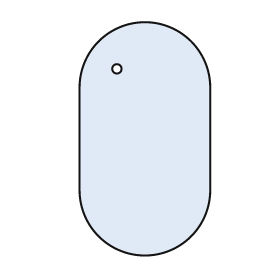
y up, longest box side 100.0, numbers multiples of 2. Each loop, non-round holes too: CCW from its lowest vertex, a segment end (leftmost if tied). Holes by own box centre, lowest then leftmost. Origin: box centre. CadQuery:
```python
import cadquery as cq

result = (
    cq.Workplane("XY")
    .moveTo(-28.0, -22.0)
    .threePointArc((0.0, -50.0), (28.0, -22.0))
    .lineTo(28.0, 22.0)
    .threePointArc((0.0, 50.0), (-28.0, 22.0))
    .close()
    .moveTo(-12.0, 30.0)
    .circle(2.0)
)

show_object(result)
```